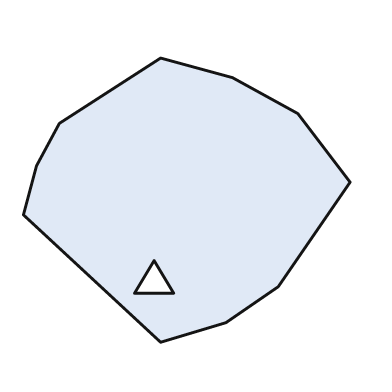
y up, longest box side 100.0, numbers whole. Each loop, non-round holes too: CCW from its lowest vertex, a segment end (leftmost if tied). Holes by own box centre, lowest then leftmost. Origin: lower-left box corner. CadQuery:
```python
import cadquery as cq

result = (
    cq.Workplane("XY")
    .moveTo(42.0, 0.0)
    .lineTo(62.0, 6.0)
    .lineTo(78.0, 17.0)
    .lineTo(100.0, 49.0)
    .lineTo(84.0, 70.0)
    .lineTo(64.0, 81.0)
    .lineTo(42.0, 87.0)
    .lineTo(11.0, 67.0)
    .lineTo(4.0, 54.0)
    .lineTo(0.0, 39.0)
    .close()
    .moveTo(34.0, 15.0)
    .lineTo(46.0, 15.0)
    .lineTo(40.0, 25.0)
    .close()
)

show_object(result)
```